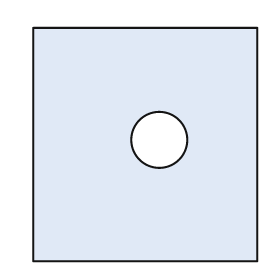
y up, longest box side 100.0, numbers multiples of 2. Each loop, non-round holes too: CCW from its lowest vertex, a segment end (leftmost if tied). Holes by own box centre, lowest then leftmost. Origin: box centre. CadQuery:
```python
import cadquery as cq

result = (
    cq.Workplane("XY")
    .moveTo(-48.0, -50.0)
    .lineTo(48.0, -50.0)
    .lineTo(48.0, 50.0)
    .lineTo(-48.0, 50.0)
    .close()
    .moveTo(6.0, 2.0)
    .circle(12.0)
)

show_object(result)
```